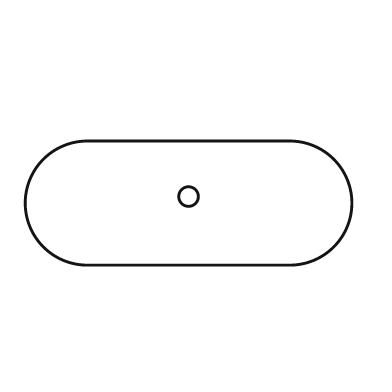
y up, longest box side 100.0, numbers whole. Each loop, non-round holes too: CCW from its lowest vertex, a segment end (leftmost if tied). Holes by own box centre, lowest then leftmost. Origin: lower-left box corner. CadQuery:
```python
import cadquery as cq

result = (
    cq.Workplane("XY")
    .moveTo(19.0, 0.0)
    .lineTo(81.0, 0.0)
    .threePointArc((100.0, 19.0), (81.0, 38.0))
    .lineTo(19.0, 38.0)
    .threePointArc((0.0, 19.0), (19.0, 0.0))
    .close()
    .moveTo(50.0, 21.0)
    .circle(3.0)
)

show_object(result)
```